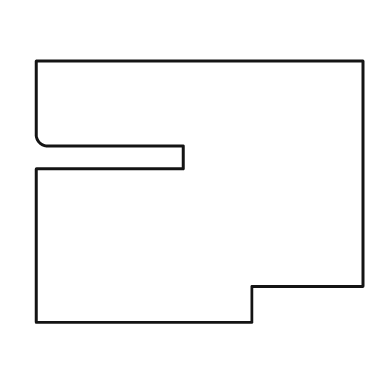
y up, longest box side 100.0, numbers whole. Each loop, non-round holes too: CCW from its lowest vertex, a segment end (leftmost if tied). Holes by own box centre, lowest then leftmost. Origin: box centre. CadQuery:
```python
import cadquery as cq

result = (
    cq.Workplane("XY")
    .moveTo(-50.0, -40.0)
    .lineTo(16.0, -40.0)
    .lineTo(16.0, -29.0)
    .lineTo(50.0, -29.0)
    .lineTo(50.0, 40.0)
    .lineTo(-50.0, 40.0)
    .lineTo(-50.0, 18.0)
    .threePointArc((-49.0, 15.0), (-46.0, 14.0))
    .lineTo(-5.0, 14.0)
    .lineTo(-5.0, 7.0)
    .lineTo(-50.0, 7.0)
    .close()
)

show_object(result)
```